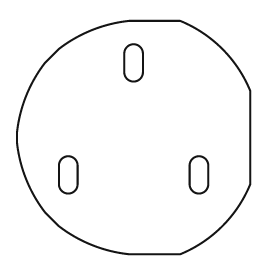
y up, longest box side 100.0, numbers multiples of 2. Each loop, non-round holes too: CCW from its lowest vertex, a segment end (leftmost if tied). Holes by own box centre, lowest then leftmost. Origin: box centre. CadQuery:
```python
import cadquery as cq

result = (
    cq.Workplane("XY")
    .moveTo(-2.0, -50.0)
    .lineTo(20.0, -50.0)
    .threePointArc((38.0, -38.0), (50.0, -20.0))
    .lineTo(50.0, 20.0)
    .threePointArc((38.0, 38.0), (20.0, 50.0))
    .lineTo(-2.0, 50.0)
    .threePointArc((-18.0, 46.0), (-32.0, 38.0))
    .lineTo(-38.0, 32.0)
    .threePointArc((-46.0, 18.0), (-50.0, 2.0))
    .lineTo(-50.0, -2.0)
    .threePointArc((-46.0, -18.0), (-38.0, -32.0))
    .lineTo(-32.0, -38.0)
    .threePointArc((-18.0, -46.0), (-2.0, -50.0))
    .close()
    .moveTo(-32.0, -20.0)
    .threePointArc((-28.0, -24.0), (-24.0, -20.0))
    .lineTo(-24.0, -12.0)
    .threePointArc((-28.0, -8.0), (-32.0, -12.0))
    .close()
    .moveTo(24.0, -20.0)
    .threePointArc((28.0, -24.0), (32.0, -20.0))
    .lineTo(32.0, -12.0)
    .threePointArc((28.0, -8.0), (24.0, -12.0))
    .close()
    .moveTo(-4.0, 28.0)
    .threePointArc((0.0, 24.0), (4.0, 28.0))
    .lineTo(4.0, 36.0)
    .threePointArc((0.0, 40.0), (-4.0, 36.0))
    .close()
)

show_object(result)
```